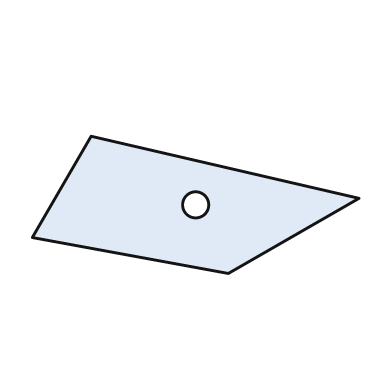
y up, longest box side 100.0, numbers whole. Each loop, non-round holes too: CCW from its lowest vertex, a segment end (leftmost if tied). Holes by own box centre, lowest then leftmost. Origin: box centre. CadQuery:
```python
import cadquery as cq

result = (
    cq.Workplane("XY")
    .moveTo(10.0, -21.0)
    .lineTo(50.0, 2.0)
    .lineTo(-32.0, 21.0)
    .lineTo(-50.0, -10.0)
    .close()
    .moveTo(0.0, 0.0)
    .circle(4.0)
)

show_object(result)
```